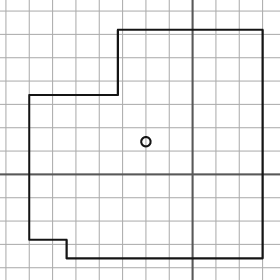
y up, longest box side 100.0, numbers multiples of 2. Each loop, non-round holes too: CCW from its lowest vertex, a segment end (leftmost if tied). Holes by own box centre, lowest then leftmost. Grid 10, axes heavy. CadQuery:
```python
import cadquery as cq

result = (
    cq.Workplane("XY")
    .moveTo(-54.0, -36.0)
    .lineTo(30.0, -36.0)
    .lineTo(30.0, 62.0)
    .lineTo(-32.0, 62.0)
    .lineTo(-32.0, 34.0)
    .lineTo(-70.0, 34.0)
    .lineTo(-70.0, -28.0)
    .lineTo(-54.0, -28.0)
    .close()
    .moveTo(-20.0, 14.0)
    .circle(2.0)
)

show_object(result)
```